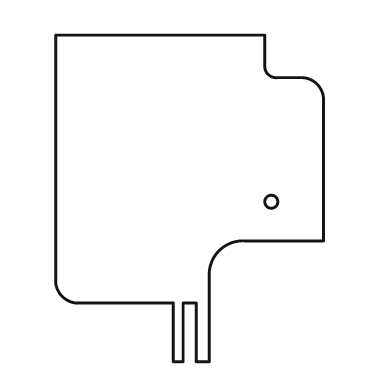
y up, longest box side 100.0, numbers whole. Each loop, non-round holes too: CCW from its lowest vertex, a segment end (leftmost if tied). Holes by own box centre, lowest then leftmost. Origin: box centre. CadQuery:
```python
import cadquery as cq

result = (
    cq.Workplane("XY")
    .moveTo(-5.0, -50.0)
    .lineTo(-2.0, -50.0)
    .lineTo(-2.0, -32.0)
    .lineTo(2.0, -32.0)
    .lineTo(2.0, -50.0)
    .lineTo(6.0, -50.0)
    .lineTo(6.0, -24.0)
    .threePointArc((9.0, -16.0), (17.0, -13.0))
    .lineTo(41.0, -13.0)
    .lineTo(41.0, 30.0)
    .threePointArc((39.0, 35.0), (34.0, 37.0))
    .lineTo(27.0, 37.0)
    .threePointArc((24.0, 38.0), (23.0, 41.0))
    .lineTo(23.0, 50.0)
    .lineTo(-41.0, 50.0)
    .lineTo(-41.0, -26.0)
    .threePointArc((-39.0, -30.0), (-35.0, -32.0))
    .lineTo(-5.0, -32.0)
    .close()
    .moveTo(25.0, -1.0)
    .circle(2.0)
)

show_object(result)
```